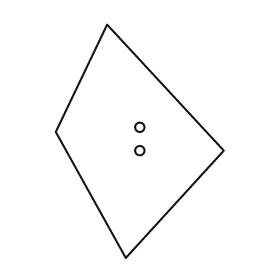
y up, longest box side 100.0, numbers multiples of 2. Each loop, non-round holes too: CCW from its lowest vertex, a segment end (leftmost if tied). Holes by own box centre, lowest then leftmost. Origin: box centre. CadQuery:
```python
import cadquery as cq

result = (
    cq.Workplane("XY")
    .moveTo(-6.0, -50.0)
    .lineTo(36.0, -4.0)
    .lineTo(-14.0, 50.0)
    .lineTo(-36.0, 4.0)
    .close()
    .moveTo(0.0, -4.0)
    .circle(2.0)
    .moveTo(0.0, 6.0)
    .circle(2.0)
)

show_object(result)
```